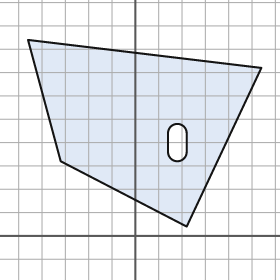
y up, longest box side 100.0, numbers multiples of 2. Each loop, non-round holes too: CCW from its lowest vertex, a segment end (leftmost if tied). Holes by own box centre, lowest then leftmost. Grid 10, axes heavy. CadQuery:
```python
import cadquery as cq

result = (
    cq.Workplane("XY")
    .moveTo(22.0, 4.0)
    .lineTo(54.0, 72.0)
    .lineTo(-46.0, 84.0)
    .lineTo(-32.0, 32.0)
    .close()
    .moveTo(14.0, 36.0)
    .threePointArc((18.0, 32.0), (22.0, 36.0))
    .lineTo(22.0, 44.0)
    .threePointArc((18.0, 48.0), (14.0, 44.0))
    .close()
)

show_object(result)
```